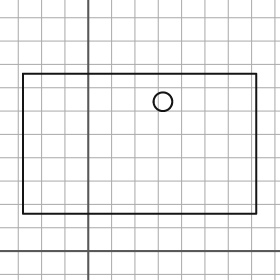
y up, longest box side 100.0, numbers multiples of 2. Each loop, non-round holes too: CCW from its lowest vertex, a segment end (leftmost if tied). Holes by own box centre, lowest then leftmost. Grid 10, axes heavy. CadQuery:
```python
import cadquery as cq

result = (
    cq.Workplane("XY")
    .moveTo(-28.0, 16.0)
    .lineTo(72.0, 16.0)
    .lineTo(72.0, 76.0)
    .lineTo(-28.0, 76.0)
    .close()
    .moveTo(32.0, 64.0)
    .circle(4.0)
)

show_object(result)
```